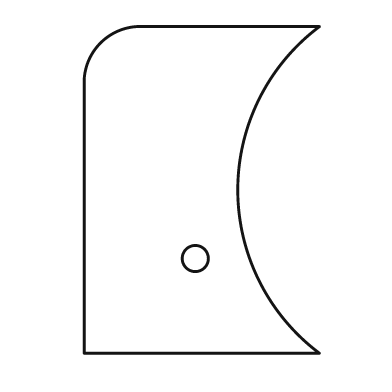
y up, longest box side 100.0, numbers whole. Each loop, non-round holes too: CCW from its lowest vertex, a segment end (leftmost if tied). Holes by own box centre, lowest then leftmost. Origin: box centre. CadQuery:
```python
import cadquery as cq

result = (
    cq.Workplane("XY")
    .moveTo(-36.0, -50.0)
    .lineTo(36.0, -50.0)
    .threePointArc((11.0, 0.0), (36.0, 50.0))
    .lineTo(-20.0, 50.0)
    .threePointArc((-31.0, 45.0), (-36.0, 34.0))
    .close()
    .moveTo(-2.0, -21.0)
    .circle(4.0)
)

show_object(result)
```